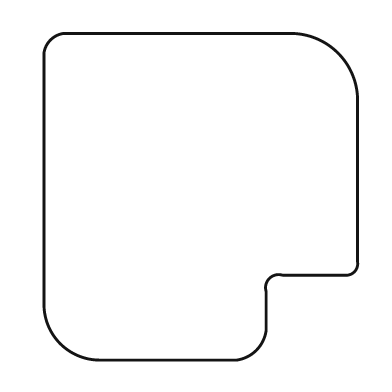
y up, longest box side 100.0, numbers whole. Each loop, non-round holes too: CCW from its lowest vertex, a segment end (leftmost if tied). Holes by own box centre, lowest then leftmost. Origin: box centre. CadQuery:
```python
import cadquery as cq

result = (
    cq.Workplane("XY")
    .moveTo(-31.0, -50.0)
    .lineTo(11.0, -50.0)
    .threePointArc((17.0, -47.0), (20.0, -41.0))
    .lineTo(20.0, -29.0)
    .threePointArc((21.0, -25.0), (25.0, -24.0))
    .lineTo(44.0, -24.0)
    .threePointArc((47.0, -23.0), (48.0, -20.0))
    .lineTo(48.0, 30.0)
    .threePointArc((42.0, 44.0), (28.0, 50.0))
    .lineTo(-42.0, 50.0)
    .threePointArc((-46.0, 48.0), (-48.0, 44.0))
    .lineTo(-48.0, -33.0)
    .threePointArc((-43.0, -45.0), (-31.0, -50.0))
    .close()
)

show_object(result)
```